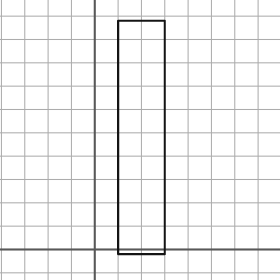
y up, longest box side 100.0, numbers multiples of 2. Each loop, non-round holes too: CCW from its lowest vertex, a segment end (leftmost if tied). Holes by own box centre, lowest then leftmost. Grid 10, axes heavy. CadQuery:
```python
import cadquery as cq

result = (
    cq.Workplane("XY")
    .moveTo(10.0, -2.0)
    .lineTo(30.0, -2.0)
    .lineTo(30.0, 98.0)
    .lineTo(10.0, 98.0)
    .close()
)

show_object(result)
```